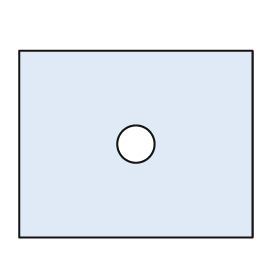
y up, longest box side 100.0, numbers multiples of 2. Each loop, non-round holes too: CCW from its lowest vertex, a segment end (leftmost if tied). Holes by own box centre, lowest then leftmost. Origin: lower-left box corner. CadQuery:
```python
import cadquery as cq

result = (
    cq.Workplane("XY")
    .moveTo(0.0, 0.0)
    .lineTo(100.0, 0.0)
    .lineTo(100.0, 80.0)
    .lineTo(0.0, 80.0)
    .close()
    .moveTo(50.0, 40.0)
    .circle(8.0)
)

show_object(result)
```